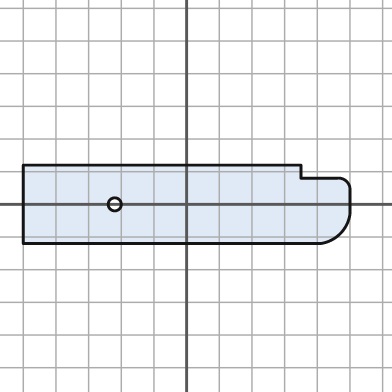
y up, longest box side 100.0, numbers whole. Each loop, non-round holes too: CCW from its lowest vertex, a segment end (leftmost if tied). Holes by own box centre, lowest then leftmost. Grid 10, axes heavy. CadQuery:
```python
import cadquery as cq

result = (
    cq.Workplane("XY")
    .moveTo(-50.0, -12.0)
    .lineTo(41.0, -12.0)
    .threePointArc((47.0, -9.0), (50.0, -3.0))
    .lineTo(50.0, 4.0)
    .threePointArc((49.0, 7.0), (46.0, 8.0))
    .lineTo(35.0, 8.0)
    .lineTo(35.0, 12.0)
    .lineTo(-50.0, 12.0)
    .close()
    .moveTo(-22.0, 0.0)
    .circle(2.0)
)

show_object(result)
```